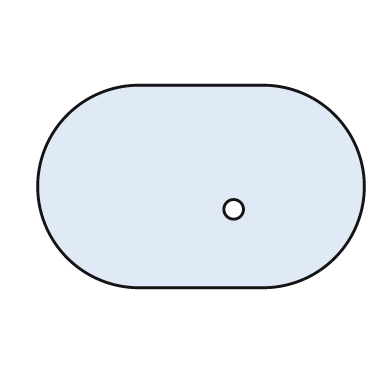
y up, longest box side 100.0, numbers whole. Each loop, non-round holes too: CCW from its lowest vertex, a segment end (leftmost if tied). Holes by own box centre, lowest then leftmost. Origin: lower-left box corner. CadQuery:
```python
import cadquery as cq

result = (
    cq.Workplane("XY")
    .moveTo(31.0, 0.0)
    .lineTo(69.0, 0.0)
    .threePointArc((100.0, 31.0), (69.0, 62.0))
    .lineTo(31.0, 62.0)
    .threePointArc((0.0, 31.0), (31.0, 0.0))
    .close()
    .moveTo(60.0, 24.0)
    .circle(3.0)
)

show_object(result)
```